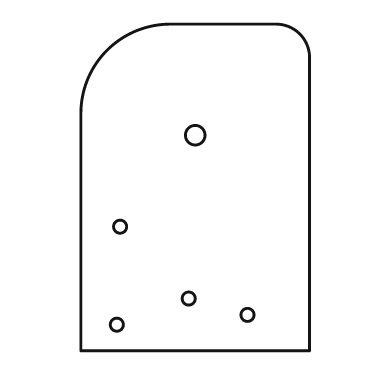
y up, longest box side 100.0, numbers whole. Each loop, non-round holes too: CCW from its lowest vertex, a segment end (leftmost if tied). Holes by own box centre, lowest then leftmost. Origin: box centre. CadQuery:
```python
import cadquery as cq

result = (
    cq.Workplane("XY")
    .moveTo(-35.0, -50.0)
    .lineTo(35.0, -50.0)
    .lineTo(35.0, 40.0)
    .threePointArc((32.0, 47.0), (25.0, 50.0))
    .lineTo(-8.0, 50.0)
    .threePointArc((-27.0, 42.0), (-35.0, 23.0))
    .close()
    .moveTo(-24.0, -42.0)
    .circle(2.0)
    .moveTo(16.0, -39.0)
    .circle(2.0)
    .moveTo(-2.0, -34.0)
    .circle(2.0)
    .moveTo(-23.0, -12.0)
    .circle(2.0)
    .moveTo(0.0, 16.0)
    .circle(3.0)
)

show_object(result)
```